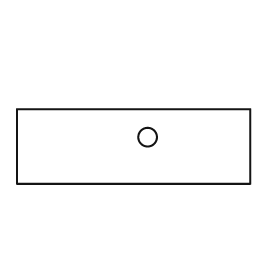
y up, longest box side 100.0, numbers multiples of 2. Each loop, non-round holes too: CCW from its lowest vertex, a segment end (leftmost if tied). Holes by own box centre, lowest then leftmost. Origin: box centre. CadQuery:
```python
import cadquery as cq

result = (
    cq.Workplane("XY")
    .moveTo(-50.0, -16.0)
    .lineTo(50.0, -16.0)
    .lineTo(50.0, 16.0)
    .lineTo(-50.0, 16.0)
    .close()
    .moveTo(6.0, 4.0)
    .circle(4.0)
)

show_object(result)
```